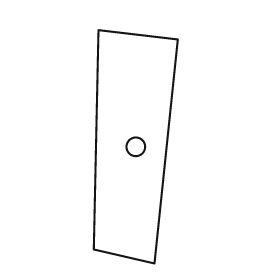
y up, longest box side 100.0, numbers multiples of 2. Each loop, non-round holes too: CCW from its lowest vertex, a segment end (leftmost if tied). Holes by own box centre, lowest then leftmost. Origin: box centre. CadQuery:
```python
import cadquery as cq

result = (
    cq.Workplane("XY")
    .moveTo(8.0, -50.0)
    .lineTo(18.0, 46.0)
    .lineTo(-16.0, 50.0)
    .lineTo(-18.0, -44.0)
    .close()
    .moveTo(0.0, 0.0)
    .circle(4.0)
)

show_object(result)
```